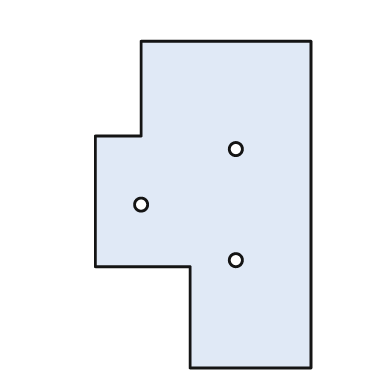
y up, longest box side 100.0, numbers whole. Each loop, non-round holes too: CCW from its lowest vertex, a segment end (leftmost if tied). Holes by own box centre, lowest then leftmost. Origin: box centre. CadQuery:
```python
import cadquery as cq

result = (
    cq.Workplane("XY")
    .moveTo(-4.0, -50.0)
    .lineTo(33.0, -50.0)
    .lineTo(33.0, 50.0)
    .lineTo(-19.0, 50.0)
    .lineTo(-19.0, 21.0)
    .lineTo(-33.0, 21.0)
    .lineTo(-33.0, -19.0)
    .lineTo(-4.0, -19.0)
    .close()
    .moveTo(10.0, -17.0)
    .circle(2.0)
    .moveTo(-19.0, 0.0)
    .circle(2.0)
    .moveTo(10.0, 17.0)
    .circle(2.0)
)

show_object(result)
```